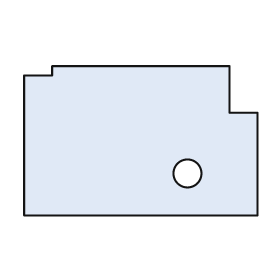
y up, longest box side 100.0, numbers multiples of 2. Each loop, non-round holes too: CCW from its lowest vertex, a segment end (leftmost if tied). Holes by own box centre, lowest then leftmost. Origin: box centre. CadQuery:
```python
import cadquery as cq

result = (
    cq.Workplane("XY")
    .moveTo(-50.0, -32.0)
    .lineTo(50.0, -32.0)
    .lineTo(50.0, 12.0)
    .lineTo(38.0, 12.0)
    .lineTo(38.0, 32.0)
    .lineTo(-38.0, 32.0)
    .lineTo(-38.0, 28.0)
    .lineTo(-50.0, 28.0)
    .close()
    .moveTo(20.0, -14.0)
    .circle(6.0)
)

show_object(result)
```